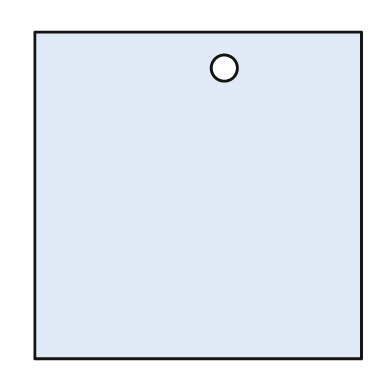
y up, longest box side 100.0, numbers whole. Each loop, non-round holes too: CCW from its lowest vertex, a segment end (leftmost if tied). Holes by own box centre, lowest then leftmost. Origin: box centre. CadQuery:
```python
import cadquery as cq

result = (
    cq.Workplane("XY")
    .moveTo(-50.0, -50.0)
    .lineTo(50.0, -50.0)
    .lineTo(50.0, 50.0)
    .lineTo(-50.0, 50.0)
    .close()
    .moveTo(8.0, 39.0)
    .circle(4.0)
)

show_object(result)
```